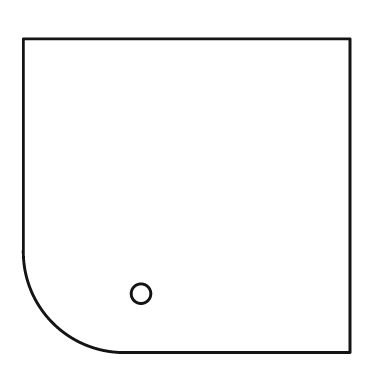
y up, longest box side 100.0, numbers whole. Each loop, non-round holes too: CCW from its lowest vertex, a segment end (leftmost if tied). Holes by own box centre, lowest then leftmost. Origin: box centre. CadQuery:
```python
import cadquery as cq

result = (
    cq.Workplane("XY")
    .moveTo(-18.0, -48.0)
    .lineTo(50.0, -48.0)
    .lineTo(50.0, 48.0)
    .lineTo(-50.0, 48.0)
    .lineTo(-50.0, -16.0)
    .threePointArc((-41.0, -39.0), (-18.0, -48.0))
    .close()
    .moveTo(-14.0, -30.0)
    .circle(3.0)
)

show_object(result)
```